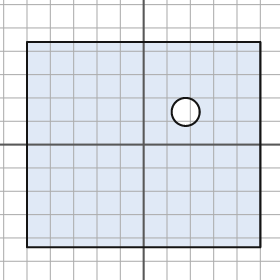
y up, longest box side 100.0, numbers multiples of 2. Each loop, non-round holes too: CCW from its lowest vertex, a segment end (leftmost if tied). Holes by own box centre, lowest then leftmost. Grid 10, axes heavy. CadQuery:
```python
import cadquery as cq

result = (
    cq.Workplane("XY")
    .moveTo(-50.0, -44.0)
    .lineTo(50.0, -44.0)
    .lineTo(50.0, 44.0)
    .lineTo(-50.0, 44.0)
    .close()
    .moveTo(18.0, 14.0)
    .circle(6.0)
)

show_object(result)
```